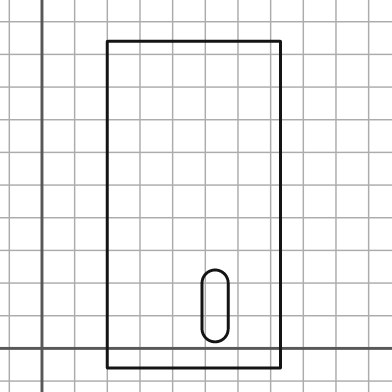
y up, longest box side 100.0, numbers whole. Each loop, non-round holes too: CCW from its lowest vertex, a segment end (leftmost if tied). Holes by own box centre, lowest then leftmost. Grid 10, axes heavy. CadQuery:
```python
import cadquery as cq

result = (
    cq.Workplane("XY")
    .moveTo(20.0, -6.0)
    .lineTo(73.0, -6.0)
    .lineTo(73.0, 94.0)
    .lineTo(20.0, 94.0)
    .close()
    .moveTo(49.0, 6.0)
    .threePointArc((53.0, 2.0), (57.0, 6.0))
    .lineTo(57.0, 20.0)
    .threePointArc((53.0, 24.0), (49.0, 20.0))
    .close()
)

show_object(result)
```